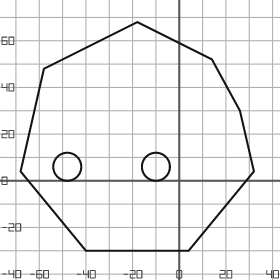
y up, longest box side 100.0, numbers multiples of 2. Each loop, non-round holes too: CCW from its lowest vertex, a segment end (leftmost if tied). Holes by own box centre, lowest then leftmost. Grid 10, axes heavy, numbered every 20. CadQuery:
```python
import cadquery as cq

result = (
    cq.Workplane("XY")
    .moveTo(-40.0, -30.0)
    .lineTo(4.0, -30.0)
    .lineTo(32.0, 4.0)
    .lineTo(26.0, 30.0)
    .lineTo(14.0, 52.0)
    .lineTo(-18.0, 68.0)
    .lineTo(-58.0, 48.0)
    .lineTo(-68.0, 4.0)
    .close()
    .moveTo(-48.0, 6.0)
    .circle(6.0)
    .moveTo(-10.0, 6.0)
    .circle(6.0)
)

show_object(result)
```